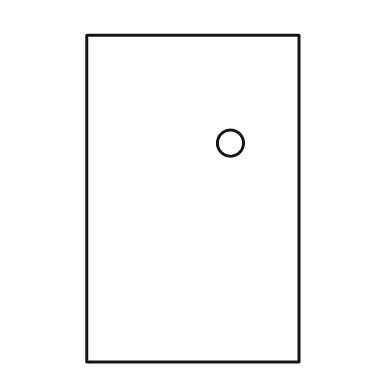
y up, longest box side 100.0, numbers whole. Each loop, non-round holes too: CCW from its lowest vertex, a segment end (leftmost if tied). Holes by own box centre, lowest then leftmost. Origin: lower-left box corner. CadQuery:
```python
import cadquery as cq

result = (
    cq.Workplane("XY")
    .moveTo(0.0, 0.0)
    .lineTo(65.0, 0.0)
    .lineTo(65.0, 100.0)
    .lineTo(0.0, 100.0)
    .close()
    .moveTo(44.0, 67.0)
    .circle(4.0)
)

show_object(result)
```